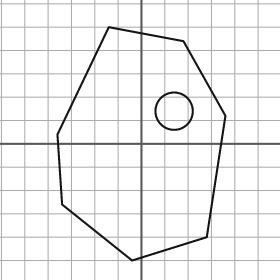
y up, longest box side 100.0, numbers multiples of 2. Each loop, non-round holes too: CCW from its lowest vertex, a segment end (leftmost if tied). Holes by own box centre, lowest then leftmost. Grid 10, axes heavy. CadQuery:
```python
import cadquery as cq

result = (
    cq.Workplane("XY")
    .moveTo(-4.0, -50.0)
    .lineTo(28.0, -40.0)
    .lineTo(36.0, 12.0)
    .lineTo(18.0, 44.0)
    .lineTo(-14.0, 50.0)
    .lineTo(-36.0, 4.0)
    .lineTo(-34.0, -26.0)
    .close()
    .moveTo(14.0, 14.0)
    .circle(8.0)
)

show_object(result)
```